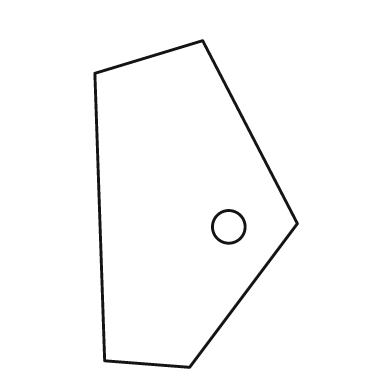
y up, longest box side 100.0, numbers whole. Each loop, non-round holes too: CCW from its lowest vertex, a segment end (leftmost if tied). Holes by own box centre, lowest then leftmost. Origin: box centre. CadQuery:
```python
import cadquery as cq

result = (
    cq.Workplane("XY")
    .moveTo(-2.0, -50.0)
    .lineTo(31.0, -6.0)
    .lineTo(2.0, 50.0)
    .lineTo(-31.0, 40.0)
    .lineTo(-28.0, -48.0)
    .close()
    .moveTo(10.0, -7.0)
    .circle(5.0)
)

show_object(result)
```